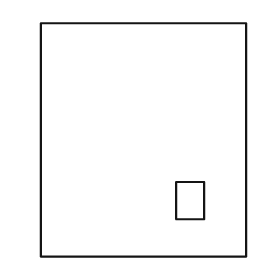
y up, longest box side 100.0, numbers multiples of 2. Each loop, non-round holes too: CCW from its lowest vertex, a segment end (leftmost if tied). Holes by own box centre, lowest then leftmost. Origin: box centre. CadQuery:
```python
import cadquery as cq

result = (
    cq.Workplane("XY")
    .moveTo(-44.0, -50.0)
    .lineTo(44.0, -50.0)
    .lineTo(44.0, 50.0)
    .lineTo(-44.0, 50.0)
    .close()
    .moveTo(14.0, -34.0)
    .lineTo(26.0, -34.0)
    .lineTo(26.0, -18.0)
    .lineTo(14.0, -18.0)
    .close()
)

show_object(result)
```